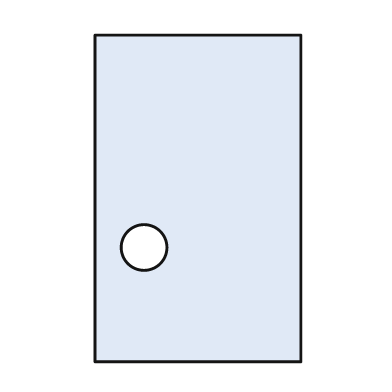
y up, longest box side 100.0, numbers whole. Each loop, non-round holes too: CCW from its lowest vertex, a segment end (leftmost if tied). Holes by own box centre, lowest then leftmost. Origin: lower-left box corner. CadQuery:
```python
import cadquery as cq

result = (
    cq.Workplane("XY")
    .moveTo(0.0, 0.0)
    .lineTo(63.0, 0.0)
    .lineTo(63.0, 100.0)
    .lineTo(0.0, 100.0)
    .close()
    .moveTo(15.0, 35.0)
    .circle(7.0)
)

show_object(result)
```